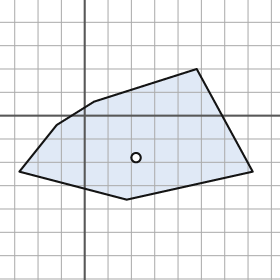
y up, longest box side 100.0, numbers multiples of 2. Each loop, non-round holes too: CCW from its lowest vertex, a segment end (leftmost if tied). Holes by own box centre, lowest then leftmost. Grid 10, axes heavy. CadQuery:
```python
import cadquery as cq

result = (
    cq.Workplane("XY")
    .moveTo(18.0, -36.0)
    .lineTo(72.0, -24.0)
    .lineTo(48.0, 20.0)
    .lineTo(4.0, 6.0)
    .lineTo(-12.0, -4.0)
    .lineTo(-28.0, -24.0)
    .close()
    .moveTo(22.0, -18.0)
    .circle(2.0)
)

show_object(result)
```